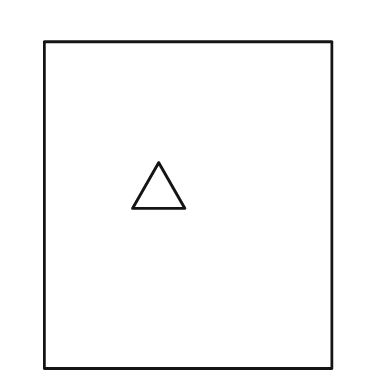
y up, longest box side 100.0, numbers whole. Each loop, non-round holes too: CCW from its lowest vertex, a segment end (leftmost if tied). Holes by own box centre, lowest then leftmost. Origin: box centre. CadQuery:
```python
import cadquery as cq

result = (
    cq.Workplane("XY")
    .moveTo(-44.0, -50.0)
    .lineTo(44.0, -50.0)
    .lineTo(44.0, 50.0)
    .lineTo(-44.0, 50.0)
    .close()
    .moveTo(-17.0, -1.0)
    .lineTo(-1.0, -1.0)
    .lineTo(-9.0, 13.0)
    .close()
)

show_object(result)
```